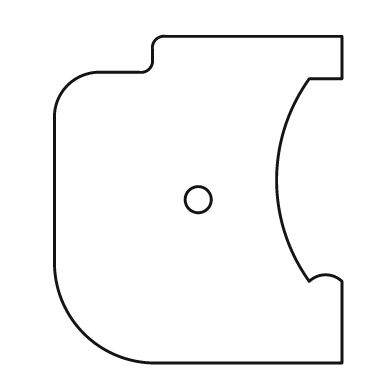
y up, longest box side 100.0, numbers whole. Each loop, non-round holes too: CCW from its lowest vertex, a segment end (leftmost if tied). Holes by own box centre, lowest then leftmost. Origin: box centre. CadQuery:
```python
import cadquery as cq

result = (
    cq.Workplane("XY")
    .moveTo(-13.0, -50.0)
    .lineTo(44.0, -50.0)
    .lineTo(44.0, -25.0)
    .threePointArc((39.0, -23.0), (34.0, -25.0))
    .threePointArc((24.0, 6.0), (34.0, 37.0))
    .lineTo(44.0, 37.0)
    .lineTo(44.0, 50.0)
    .lineTo(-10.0, 50.0)
    .threePointArc((-13.0, 49.0), (-14.0, 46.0))
    .lineTo(-14.0, 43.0)
    .threePointArc((-15.0, 40.0), (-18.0, 39.0))
    .lineTo(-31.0, 39.0)
    .threePointArc((-40.0, 35.0), (-44.0, 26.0))
    .lineTo(-44.0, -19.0)
    .threePointArc((-35.0, -41.0), (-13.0, -50.0))
    .close()
    .moveTo(0.0, 0.0)
    .circle(4.0)
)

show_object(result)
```